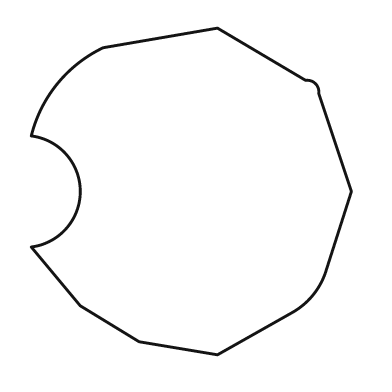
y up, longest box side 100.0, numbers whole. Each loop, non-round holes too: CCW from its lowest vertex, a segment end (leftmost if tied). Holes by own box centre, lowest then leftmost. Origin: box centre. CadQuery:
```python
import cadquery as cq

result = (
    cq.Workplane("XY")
    .moveTo(8.0, -50.0)
    .lineTo(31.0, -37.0)
    .threePointArc((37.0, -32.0), (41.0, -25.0))
    .lineTo(49.0, 0.0)
    .lineTo(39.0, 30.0)
    .threePointArc((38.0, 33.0), (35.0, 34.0))
    .lineTo(8.0, 50.0)
    .lineTo(-27.0, 44.0)
    .threePointArc((-41.0, 33.0), (-49.0, 17.0))
    .threePointArc((-34.0, 0.0), (-49.0, -17.0))
    .lineTo(-34.0, -35.0)
    .lineTo(-16.0, -46.0)
    .close()
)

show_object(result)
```